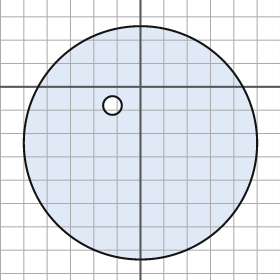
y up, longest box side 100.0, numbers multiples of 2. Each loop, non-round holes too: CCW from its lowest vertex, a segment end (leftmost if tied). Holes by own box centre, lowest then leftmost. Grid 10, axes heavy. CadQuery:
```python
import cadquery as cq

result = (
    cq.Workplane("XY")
    .moveTo(0.0, -24.0)
    .circle(50.0)
    .moveTo(-12.0, -8.0)
    .circle(4.0)
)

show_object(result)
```